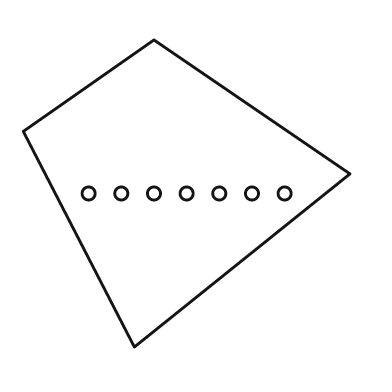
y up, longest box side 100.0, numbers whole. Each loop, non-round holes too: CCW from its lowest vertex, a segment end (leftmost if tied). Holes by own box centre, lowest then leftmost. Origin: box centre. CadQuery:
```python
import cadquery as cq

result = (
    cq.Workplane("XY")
    .moveTo(-16.0, -47.0)
    .lineTo(50.0, 6.0)
    .lineTo(-10.0, 47.0)
    .lineTo(-50.0, 19.0)
    .close()
    .moveTo(-30.0, 0.0)
    .circle(2.0)
    .moveTo(-20.0, 0.0)
    .circle(2.0)
    .moveTo(-10.0, 0.0)
    .circle(2.0)
    .moveTo(0.0, 0.0)
    .circle(2.0)
    .moveTo(10.0, 0.0)
    .circle(2.0)
    .moveTo(20.0, 0.0)
    .circle(2.0)
    .moveTo(30.0, 0.0)
    .circle(2.0)
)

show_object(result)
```